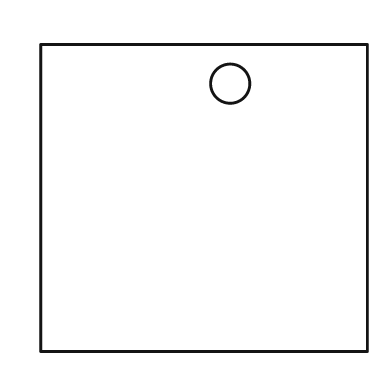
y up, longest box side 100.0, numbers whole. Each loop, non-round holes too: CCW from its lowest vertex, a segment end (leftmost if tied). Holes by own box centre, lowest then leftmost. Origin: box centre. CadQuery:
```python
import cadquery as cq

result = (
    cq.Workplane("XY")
    .moveTo(-50.0, -47.0)
    .lineTo(50.0, -47.0)
    .lineTo(50.0, 47.0)
    .lineTo(-50.0, 47.0)
    .close()
    .moveTo(8.0, 35.0)
    .circle(6.0)
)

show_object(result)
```